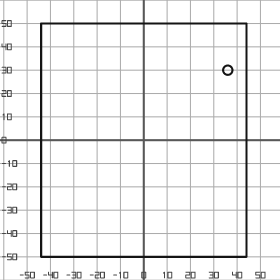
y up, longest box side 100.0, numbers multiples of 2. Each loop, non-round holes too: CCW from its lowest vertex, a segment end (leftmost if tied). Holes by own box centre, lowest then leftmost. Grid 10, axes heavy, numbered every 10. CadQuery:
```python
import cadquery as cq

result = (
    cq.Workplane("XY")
    .moveTo(-44.0, -50.0)
    .lineTo(44.0, -50.0)
    .lineTo(44.0, 50.0)
    .lineTo(-44.0, 50.0)
    .close()
    .moveTo(36.0, 30.0)
    .circle(2.0)
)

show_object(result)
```